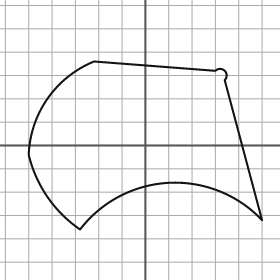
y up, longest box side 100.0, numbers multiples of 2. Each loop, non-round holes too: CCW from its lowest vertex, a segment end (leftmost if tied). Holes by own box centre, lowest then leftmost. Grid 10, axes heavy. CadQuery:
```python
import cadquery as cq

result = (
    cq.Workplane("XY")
    .moveTo(-28.0, -36.0)
    .threePointArc((10.0, -16.0), (50.0, -32.0))
    .lineTo(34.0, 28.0)
    .threePointArc((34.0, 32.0), (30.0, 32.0))
    .lineTo(-22.0, 36.0)
    .threePointArc((-42.0, 20.0), (-50.0, -4.0))
    .threePointArc((-42.0, -22.0), (-28.0, -36.0))
    .close()
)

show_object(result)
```